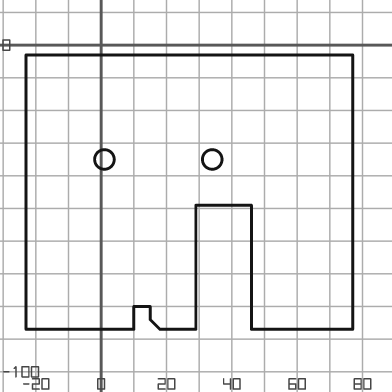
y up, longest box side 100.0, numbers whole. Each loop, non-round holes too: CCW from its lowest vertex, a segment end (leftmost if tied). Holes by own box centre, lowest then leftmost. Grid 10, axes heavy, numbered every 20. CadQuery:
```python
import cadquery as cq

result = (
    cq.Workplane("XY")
    .moveTo(-23.0, -87.0)
    .lineTo(10.0, -87.0)
    .lineTo(10.0, -80.0)
    .lineTo(15.0, -80.0)
    .lineTo(15.0, -84.0)
    .lineTo(18.0, -87.0)
    .lineTo(29.0, -87.0)
    .lineTo(29.0, -49.0)
    .lineTo(46.0, -49.0)
    .lineTo(46.0, -87.0)
    .lineTo(77.0, -87.0)
    .lineTo(77.0, -3.0)
    .lineTo(-23.0, -3.0)
    .close()
    .moveTo(1.0, -35.0)
    .circle(3.0)
    .moveTo(34.0, -35.0)
    .circle(3.0)
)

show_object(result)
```